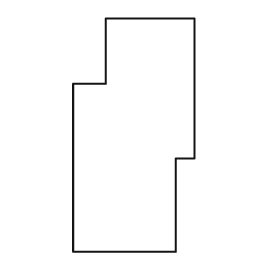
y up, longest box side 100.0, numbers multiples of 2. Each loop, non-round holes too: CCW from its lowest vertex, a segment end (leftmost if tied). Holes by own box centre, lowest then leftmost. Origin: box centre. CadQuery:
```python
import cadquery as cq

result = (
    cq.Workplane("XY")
    .moveTo(-26.0, -50.0)
    .lineTo(18.0, -50.0)
    .lineTo(18.0, -10.0)
    .lineTo(26.0, -10.0)
    .lineTo(26.0, 50.0)
    .lineTo(-12.0, 50.0)
    .lineTo(-12.0, 22.0)
    .lineTo(-26.0, 22.0)
    .close()
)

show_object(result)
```